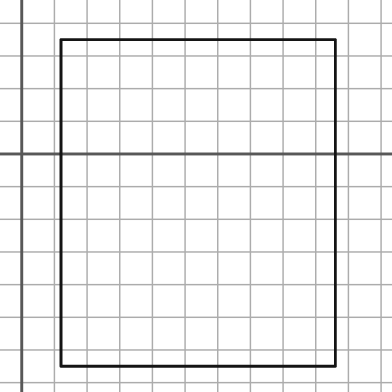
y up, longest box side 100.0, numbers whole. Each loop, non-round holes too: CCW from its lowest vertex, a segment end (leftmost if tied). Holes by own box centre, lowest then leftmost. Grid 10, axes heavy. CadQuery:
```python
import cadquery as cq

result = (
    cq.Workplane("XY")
    .moveTo(12.0, -65.0)
    .lineTo(96.0, -65.0)
    .lineTo(96.0, 35.0)
    .lineTo(12.0, 35.0)
    .close()
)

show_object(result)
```